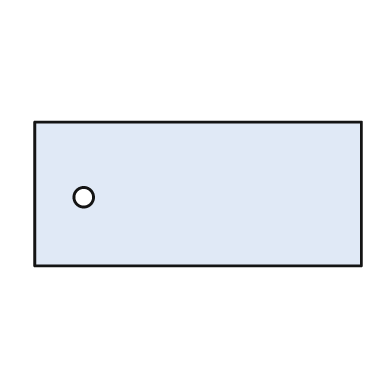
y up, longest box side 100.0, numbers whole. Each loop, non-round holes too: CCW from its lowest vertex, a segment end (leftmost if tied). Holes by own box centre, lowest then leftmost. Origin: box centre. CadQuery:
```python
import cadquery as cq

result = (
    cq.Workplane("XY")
    .moveTo(-50.0, -22.0)
    .lineTo(50.0, -22.0)
    .lineTo(50.0, 22.0)
    .lineTo(-50.0, 22.0)
    .close()
    .moveTo(-35.0, -1.0)
    .circle(3.0)
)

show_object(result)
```